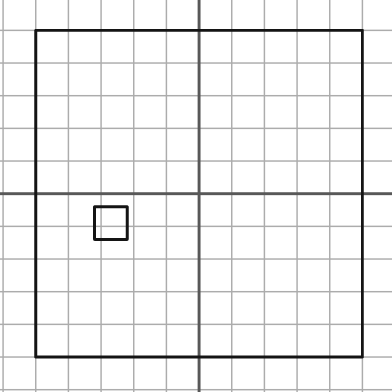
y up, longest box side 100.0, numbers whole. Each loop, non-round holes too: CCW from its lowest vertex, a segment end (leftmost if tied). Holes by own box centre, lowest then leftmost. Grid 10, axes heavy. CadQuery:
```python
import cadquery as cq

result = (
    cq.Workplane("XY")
    .moveTo(-50.0, -50.0)
    .lineTo(50.0, -50.0)
    .lineTo(50.0, 50.0)
    .lineTo(-50.0, 50.0)
    .close()
    .moveTo(-32.0, -14.0)
    .lineTo(-22.0, -14.0)
    .lineTo(-22.0, -4.0)
    .lineTo(-32.0, -4.0)
    .close()
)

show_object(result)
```